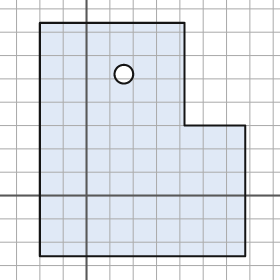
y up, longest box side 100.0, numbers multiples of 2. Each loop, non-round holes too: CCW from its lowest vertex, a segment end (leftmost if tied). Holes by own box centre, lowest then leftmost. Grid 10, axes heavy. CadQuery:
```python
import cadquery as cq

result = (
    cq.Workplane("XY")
    .moveTo(-20.0, -26.0)
    .lineTo(68.0, -26.0)
    .lineTo(68.0, 30.0)
    .lineTo(42.0, 30.0)
    .lineTo(42.0, 74.0)
    .lineTo(-20.0, 74.0)
    .close()
    .moveTo(16.0, 52.0)
    .circle(4.0)
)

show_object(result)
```